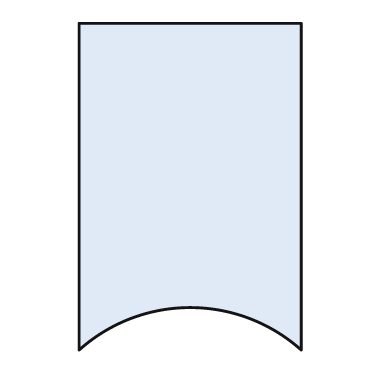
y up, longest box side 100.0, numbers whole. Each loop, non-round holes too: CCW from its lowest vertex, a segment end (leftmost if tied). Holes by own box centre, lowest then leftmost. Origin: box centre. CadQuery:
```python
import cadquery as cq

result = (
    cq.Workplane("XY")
    .moveTo(-34.0, -50.0)
    .threePointArc((0.0, -37.0), (34.0, -50.0))
    .lineTo(34.0, 50.0)
    .lineTo(-34.0, 50.0)
    .close()
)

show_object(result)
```